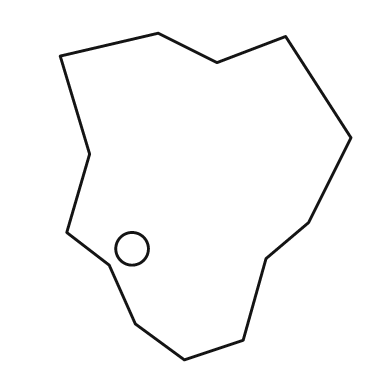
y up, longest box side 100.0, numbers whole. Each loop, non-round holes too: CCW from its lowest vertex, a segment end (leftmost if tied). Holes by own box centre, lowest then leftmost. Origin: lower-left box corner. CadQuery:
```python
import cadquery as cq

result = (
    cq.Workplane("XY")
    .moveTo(38.0, 0.0)
    .lineTo(56.0, 6.0)
    .lineTo(63.0, 31.0)
    .lineTo(76.0, 42.0)
    .lineTo(89.0, 68.0)
    .lineTo(69.0, 99.0)
    .lineTo(48.0, 91.0)
    .lineTo(30.0, 100.0)
    .lineTo(0.0, 93.0)
    .lineTo(9.0, 63.0)
    .lineTo(2.0, 39.0)
    .lineTo(15.0, 29.0)
    .lineTo(23.0, 11.0)
    .close()
    .moveTo(22.0, 34.0)
    .circle(5.0)
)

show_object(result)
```